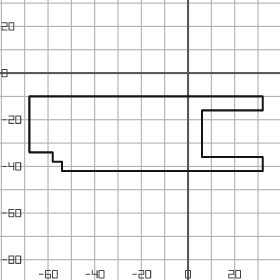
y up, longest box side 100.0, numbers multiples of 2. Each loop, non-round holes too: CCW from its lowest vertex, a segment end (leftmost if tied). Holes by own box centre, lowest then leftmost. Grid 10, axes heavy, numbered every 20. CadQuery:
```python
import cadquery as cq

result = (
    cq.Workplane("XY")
    .moveTo(-54.0, -42.0)
    .lineTo(32.0, -42.0)
    .lineTo(32.0, -36.0)
    .lineTo(6.0, -36.0)
    .lineTo(6.0, -16.0)
    .lineTo(32.0, -16.0)
    .lineTo(32.0, -10.0)
    .lineTo(-68.0, -10.0)
    .lineTo(-68.0, -34.0)
    .lineTo(-58.0, -34.0)
    .lineTo(-58.0, -38.0)
    .lineTo(-54.0, -38.0)
    .close()
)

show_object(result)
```